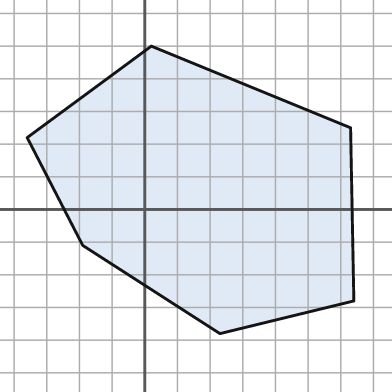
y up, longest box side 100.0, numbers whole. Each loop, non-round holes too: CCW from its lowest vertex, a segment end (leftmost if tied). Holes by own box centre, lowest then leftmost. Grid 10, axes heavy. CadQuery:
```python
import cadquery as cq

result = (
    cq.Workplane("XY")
    .moveTo(23.0, -38.0)
    .lineTo(64.0, -28.0)
    .lineTo(63.0, 25.0)
    .lineTo(2.0, 50.0)
    .lineTo(-36.0, 22.0)
    .lineTo(-19.0, -11.0)
    .close()
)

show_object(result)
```